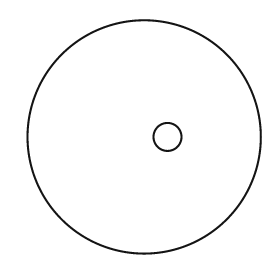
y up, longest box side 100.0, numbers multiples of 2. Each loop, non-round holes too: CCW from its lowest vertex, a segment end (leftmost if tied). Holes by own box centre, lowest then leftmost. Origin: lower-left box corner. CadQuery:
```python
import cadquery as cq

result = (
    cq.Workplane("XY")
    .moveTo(50.0, 50.0)
    .circle(50.0)
    .moveTo(60.0, 50.0)
    .circle(6.0)
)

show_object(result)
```